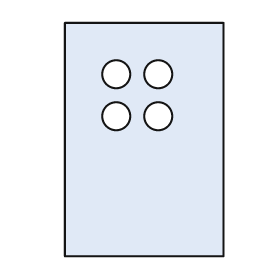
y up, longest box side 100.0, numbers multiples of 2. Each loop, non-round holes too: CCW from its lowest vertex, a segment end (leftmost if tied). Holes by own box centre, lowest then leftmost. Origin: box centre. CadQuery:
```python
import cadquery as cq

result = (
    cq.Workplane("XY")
    .moveTo(-34.0, -50.0)
    .lineTo(34.0, -50.0)
    .lineTo(34.0, 50.0)
    .lineTo(-34.0, 50.0)
    .close()
    .moveTo(-12.0, 10.0)
    .circle(6.0)
    .moveTo(6.0, 10.0)
    .circle(6.0)
    .moveTo(-12.0, 28.0)
    .circle(6.0)
    .moveTo(6.0, 28.0)
    .circle(6.0)
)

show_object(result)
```